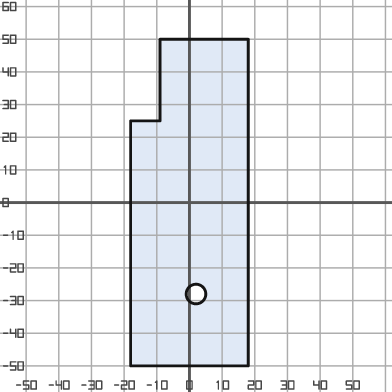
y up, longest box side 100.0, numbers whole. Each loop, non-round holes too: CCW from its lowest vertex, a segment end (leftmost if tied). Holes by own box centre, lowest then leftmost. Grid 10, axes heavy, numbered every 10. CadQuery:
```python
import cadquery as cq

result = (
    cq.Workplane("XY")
    .moveTo(-18.0, -50.0)
    .lineTo(18.0, -50.0)
    .lineTo(18.0, 50.0)
    .lineTo(-9.0, 50.0)
    .lineTo(-9.0, 25.0)
    .lineTo(-18.0, 25.0)
    .close()
    .moveTo(2.0, -28.0)
    .circle(3.0)
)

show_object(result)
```